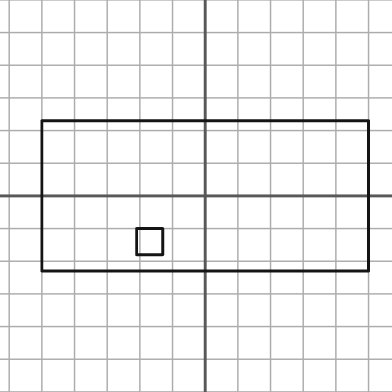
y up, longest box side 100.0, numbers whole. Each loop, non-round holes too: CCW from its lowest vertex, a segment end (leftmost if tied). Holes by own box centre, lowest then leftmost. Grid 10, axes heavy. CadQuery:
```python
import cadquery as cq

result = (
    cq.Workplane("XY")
    .moveTo(-50.0, -23.0)
    .lineTo(50.0, -23.0)
    .lineTo(50.0, 23.0)
    .lineTo(-50.0, 23.0)
    .close()
    .moveTo(-21.0, -18.0)
    .lineTo(-13.0, -18.0)
    .lineTo(-13.0, -10.0)
    .lineTo(-21.0, -10.0)
    .close()
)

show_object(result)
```